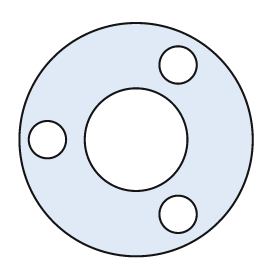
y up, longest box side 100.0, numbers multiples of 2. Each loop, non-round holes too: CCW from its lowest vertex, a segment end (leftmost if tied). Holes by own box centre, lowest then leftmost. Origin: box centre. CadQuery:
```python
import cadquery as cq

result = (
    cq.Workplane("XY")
    .moveTo(0.0, 0.0)
    .circle(50.0)
    .moveTo(18.0, -32.0)
    .circle(8.0)
    .moveTo(-38.0, 0.0)
    .circle(8.0)
    .moveTo(0.0, 0.0)
    .circle(22.0)
    .moveTo(18.0, 32.0)
    .circle(8.0)
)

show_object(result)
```